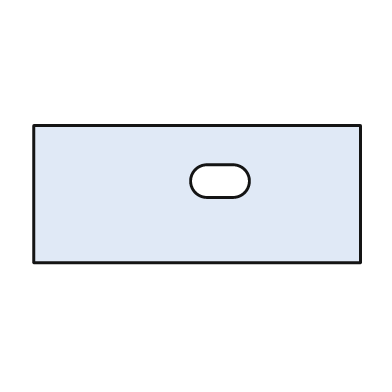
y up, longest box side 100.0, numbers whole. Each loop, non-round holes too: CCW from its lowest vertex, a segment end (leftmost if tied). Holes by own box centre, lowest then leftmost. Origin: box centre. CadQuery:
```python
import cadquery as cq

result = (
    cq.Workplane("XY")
    .moveTo(-50.0, -21.0)
    .lineTo(50.0, -21.0)
    .lineTo(50.0, 21.0)
    .lineTo(-50.0, 21.0)
    .close()
    .moveTo(3.0, -1.0)
    .lineTo(11.0, -1.0)
    .threePointArc((16.0, 4.0), (11.0, 9.0))
    .lineTo(3.0, 9.0)
    .threePointArc((-2.0, 4.0), (3.0, -1.0))
    .close()
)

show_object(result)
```